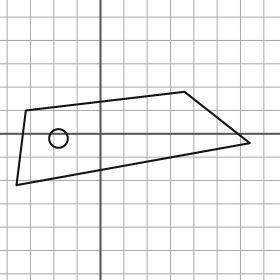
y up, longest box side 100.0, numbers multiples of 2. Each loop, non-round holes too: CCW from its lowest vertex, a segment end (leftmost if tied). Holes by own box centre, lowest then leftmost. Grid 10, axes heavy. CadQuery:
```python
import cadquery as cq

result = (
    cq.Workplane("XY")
    .moveTo(-36.0, -22.0)
    .lineTo(64.0, -4.0)
    .lineTo(36.0, 18.0)
    .lineTo(-32.0, 10.0)
    .close()
    .moveTo(-18.0, -2.0)
    .circle(4.0)
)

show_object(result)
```